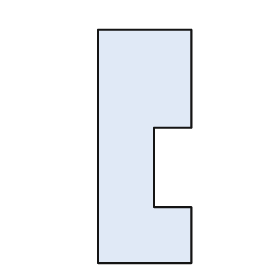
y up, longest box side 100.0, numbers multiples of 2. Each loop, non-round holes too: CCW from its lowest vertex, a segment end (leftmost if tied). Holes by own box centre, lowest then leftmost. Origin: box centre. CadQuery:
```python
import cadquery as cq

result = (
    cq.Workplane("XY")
    .moveTo(-20.0, -50.0)
    .lineTo(20.0, -50.0)
    .lineTo(20.0, -26.0)
    .lineTo(4.0, -26.0)
    .lineTo(4.0, 8.0)
    .lineTo(20.0, 8.0)
    .lineTo(20.0, 50.0)
    .lineTo(-20.0, 50.0)
    .close()
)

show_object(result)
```